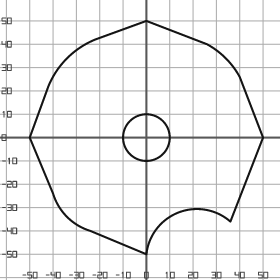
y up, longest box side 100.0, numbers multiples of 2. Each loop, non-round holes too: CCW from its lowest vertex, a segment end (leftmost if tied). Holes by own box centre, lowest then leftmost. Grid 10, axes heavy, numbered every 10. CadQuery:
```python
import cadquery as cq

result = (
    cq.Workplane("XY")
    .moveTo(0.0, -50.0)
    .threePointArc((14.0, -32.0), (36.0, -36.0))
    .lineTo(50.0, 0.0)
    .lineTo(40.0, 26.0)
    .threePointArc((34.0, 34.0), (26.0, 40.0))
    .lineTo(0.0, 50.0)
    .lineTo(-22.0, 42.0)
    .threePointArc((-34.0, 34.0), (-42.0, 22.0))
    .lineTo(-50.0, 0.0)
    .lineTo(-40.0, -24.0)
    .threePointArc((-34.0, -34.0), (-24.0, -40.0))
    .close()
    .moveTo(0.0, 0.0)
    .circle(10.0)
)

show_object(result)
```